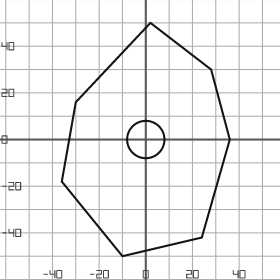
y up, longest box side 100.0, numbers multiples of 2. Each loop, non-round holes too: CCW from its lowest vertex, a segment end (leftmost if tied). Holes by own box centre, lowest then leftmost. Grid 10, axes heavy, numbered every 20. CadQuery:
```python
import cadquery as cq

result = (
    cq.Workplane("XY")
    .moveTo(-10.0, -50.0)
    .lineTo(24.0, -42.0)
    .lineTo(36.0, 0.0)
    .lineTo(28.0, 30.0)
    .lineTo(2.0, 50.0)
    .lineTo(-30.0, 16.0)
    .lineTo(-36.0, -18.0)
    .close()
    .moveTo(0.0, 0.0)
    .circle(8.0)
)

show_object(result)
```